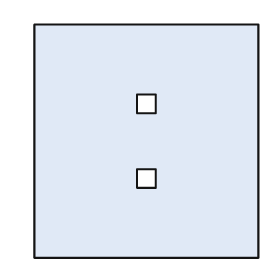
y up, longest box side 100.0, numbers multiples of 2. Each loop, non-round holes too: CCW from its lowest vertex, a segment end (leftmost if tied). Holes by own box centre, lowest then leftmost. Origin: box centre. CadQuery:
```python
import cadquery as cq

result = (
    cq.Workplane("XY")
    .moveTo(-48.0, -50.0)
    .lineTo(48.0, -50.0)
    .lineTo(48.0, 50.0)
    .lineTo(-48.0, 50.0)
    .close()
    .moveTo(-4.0, -20.0)
    .lineTo(4.0, -20.0)
    .lineTo(4.0, -12.0)
    .lineTo(-4.0, -12.0)
    .close()
    .moveTo(-4.0, 12.0)
    .lineTo(4.0, 12.0)
    .lineTo(4.0, 20.0)
    .lineTo(-4.0, 20.0)
    .close()
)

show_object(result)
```